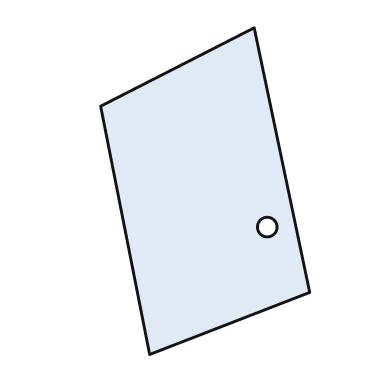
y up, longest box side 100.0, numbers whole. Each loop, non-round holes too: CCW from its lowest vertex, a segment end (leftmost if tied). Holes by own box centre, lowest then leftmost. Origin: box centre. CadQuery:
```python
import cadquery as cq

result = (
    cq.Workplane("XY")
    .moveTo(-17.0, -50.0)
    .lineTo(32.0, -31.0)
    .lineTo(15.0, 50.0)
    .lineTo(-32.0, 26.0)
    .close()
    .moveTo(19.0, -11.0)
    .circle(3.0)
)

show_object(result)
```